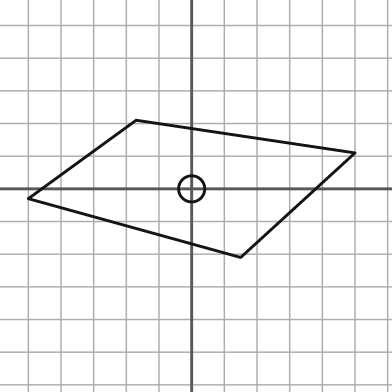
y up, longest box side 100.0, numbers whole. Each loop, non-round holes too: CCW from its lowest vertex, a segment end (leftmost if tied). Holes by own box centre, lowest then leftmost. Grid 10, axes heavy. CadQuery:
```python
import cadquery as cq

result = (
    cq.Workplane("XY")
    .moveTo(15.0, -21.0)
    .lineTo(50.0, 11.0)
    .lineTo(-17.0, 21.0)
    .lineTo(-50.0, -3.0)
    .close()
    .moveTo(0.0, 0.0)
    .circle(4.0)
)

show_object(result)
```